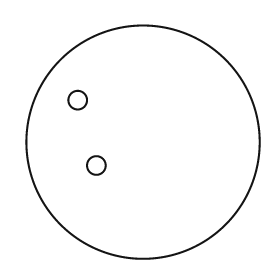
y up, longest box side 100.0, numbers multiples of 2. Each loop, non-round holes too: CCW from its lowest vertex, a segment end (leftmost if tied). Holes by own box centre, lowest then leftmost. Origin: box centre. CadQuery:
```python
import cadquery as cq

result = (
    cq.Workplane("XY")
    .moveTo(0.0, 0.0)
    .circle(50.0)
    .moveTo(-20.0, -10.0)
    .circle(4.0)
    .moveTo(-28.0, 18.0)
    .circle(4.0)
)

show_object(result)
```